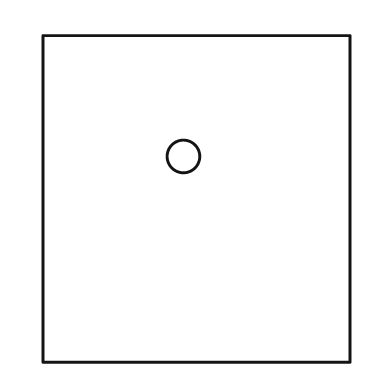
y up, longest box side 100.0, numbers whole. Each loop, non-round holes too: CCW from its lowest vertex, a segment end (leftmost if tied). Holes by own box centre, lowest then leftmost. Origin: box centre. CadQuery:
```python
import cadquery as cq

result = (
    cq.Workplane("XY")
    .moveTo(-47.0, -50.0)
    .lineTo(47.0, -50.0)
    .lineTo(47.0, 50.0)
    .lineTo(-47.0, 50.0)
    .close()
    .moveTo(-4.0, 13.0)
    .circle(5.0)
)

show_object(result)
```